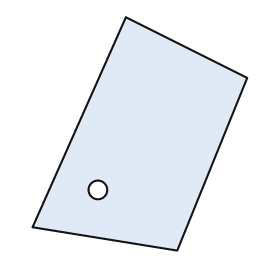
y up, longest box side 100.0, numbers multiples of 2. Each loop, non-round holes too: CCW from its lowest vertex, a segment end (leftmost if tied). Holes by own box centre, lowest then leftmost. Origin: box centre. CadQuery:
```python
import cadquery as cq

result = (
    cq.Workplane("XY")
    .moveTo(16.0, -50.0)
    .lineTo(46.0, 24.0)
    .lineTo(-6.0, 50.0)
    .lineTo(-46.0, -40.0)
    .close()
    .moveTo(-18.0, -24.0)
    .circle(4.0)
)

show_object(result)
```